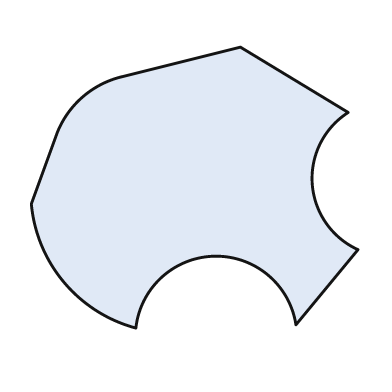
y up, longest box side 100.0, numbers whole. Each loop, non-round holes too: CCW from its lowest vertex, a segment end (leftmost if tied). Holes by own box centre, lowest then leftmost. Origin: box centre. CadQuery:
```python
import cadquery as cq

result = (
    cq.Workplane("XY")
    .moveTo(-18.0, -43.0)
    .threePointArc((6.0, -21.0), (31.0, -42.0))
    .lineTo(50.0, -19.0)
    .threePointArc((36.0, 1.0), (47.0, 23.0))
    .lineTo(14.0, 43.0)
    .lineTo(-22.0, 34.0)
    .threePointArc((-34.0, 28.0), (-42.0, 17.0))
    .lineTo(-50.0, -5.0)
    .threePointArc((-40.0, -29.0), (-18.0, -43.0))
    .close()
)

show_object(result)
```